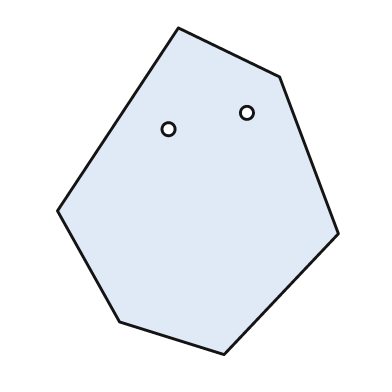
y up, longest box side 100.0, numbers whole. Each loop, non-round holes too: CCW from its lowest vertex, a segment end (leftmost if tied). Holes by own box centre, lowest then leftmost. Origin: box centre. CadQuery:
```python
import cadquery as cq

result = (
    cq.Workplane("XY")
    .moveTo(8.0, -50.0)
    .lineTo(43.0, -13.0)
    .lineTo(25.0, 35.0)
    .lineTo(-6.0, 50.0)
    .lineTo(-43.0, -6.0)
    .lineTo(-24.0, -40.0)
    .close()
    .moveTo(-9.0, 19.0)
    .circle(2.0)
    .moveTo(15.0, 24.0)
    .circle(2.0)
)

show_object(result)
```